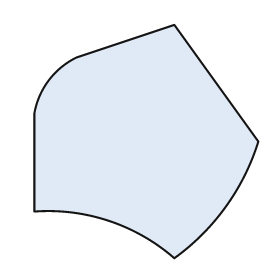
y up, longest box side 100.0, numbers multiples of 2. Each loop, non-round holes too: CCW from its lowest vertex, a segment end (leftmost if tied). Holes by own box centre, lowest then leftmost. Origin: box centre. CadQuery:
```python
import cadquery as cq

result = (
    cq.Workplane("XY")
    .moveTo(12.0, -50.0)
    .threePointArc((34.0, -28.0), (48.0, 0.0))
    .lineTo(12.0, 50.0)
    .lineTo(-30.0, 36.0)
    .threePointArc((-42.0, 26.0), (-48.0, 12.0))
    .lineTo(-48.0, -30.0)
    .threePointArc((-16.0, -34.0), (12.0, -50.0))
    .close()
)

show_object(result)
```